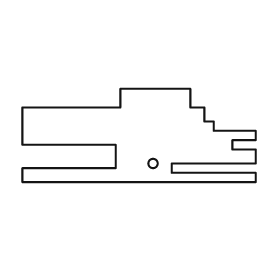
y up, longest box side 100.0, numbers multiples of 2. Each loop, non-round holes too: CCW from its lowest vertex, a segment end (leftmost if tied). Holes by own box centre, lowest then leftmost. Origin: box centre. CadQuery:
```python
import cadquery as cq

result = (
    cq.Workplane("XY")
    .moveTo(-50.0, -20.0)
    .lineTo(50.0, -20.0)
    .lineTo(50.0, -16.0)
    .lineTo(14.0, -16.0)
    .lineTo(14.0, -12.0)
    .lineTo(50.0, -12.0)
    .lineTo(50.0, -6.0)
    .lineTo(40.0, -6.0)
    .lineTo(40.0, -2.0)
    .lineTo(50.0, -2.0)
    .lineTo(50.0, 2.0)
    .lineTo(32.0, 2.0)
    .lineTo(32.0, 6.0)
    .lineTo(28.0, 6.0)
    .lineTo(28.0, 12.0)
    .lineTo(22.0, 12.0)
    .lineTo(22.0, 20.0)
    .lineTo(-8.0, 20.0)
    .lineTo(-8.0, 12.0)
    .lineTo(-50.0, 12.0)
    .lineTo(-50.0, -4.0)
    .lineTo(-10.0, -4.0)
    .lineTo(-10.0, -14.0)
    .lineTo(-50.0, -14.0)
    .close()
    .moveTo(6.0, -12.0)
    .circle(2.0)
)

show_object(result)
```